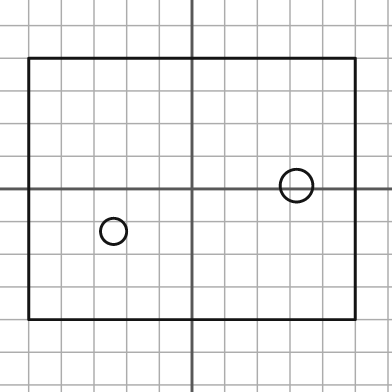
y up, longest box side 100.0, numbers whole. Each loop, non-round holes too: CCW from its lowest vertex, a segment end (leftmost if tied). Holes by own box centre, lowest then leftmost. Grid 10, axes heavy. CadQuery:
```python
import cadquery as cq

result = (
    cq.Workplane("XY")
    .moveTo(-50.0, -40.0)
    .lineTo(50.0, -40.0)
    .lineTo(50.0, 40.0)
    .lineTo(-50.0, 40.0)
    .close()
    .moveTo(-24.0, -13.0)
    .circle(4.0)
    .moveTo(32.0, 1.0)
    .circle(5.0)
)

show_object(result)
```